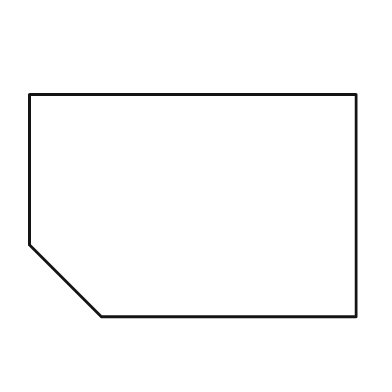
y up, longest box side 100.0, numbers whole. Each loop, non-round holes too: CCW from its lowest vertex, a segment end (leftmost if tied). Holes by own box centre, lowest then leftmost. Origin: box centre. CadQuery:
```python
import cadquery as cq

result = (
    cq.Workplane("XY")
    .moveTo(-28.0, -34.0)
    .lineTo(50.0, -34.0)
    .lineTo(50.0, 34.0)
    .lineTo(-50.0, 34.0)
    .lineTo(-50.0, -12.0)
    .close()
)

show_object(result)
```